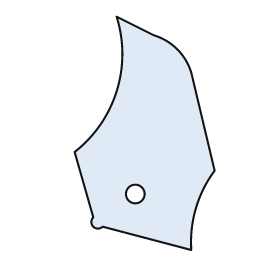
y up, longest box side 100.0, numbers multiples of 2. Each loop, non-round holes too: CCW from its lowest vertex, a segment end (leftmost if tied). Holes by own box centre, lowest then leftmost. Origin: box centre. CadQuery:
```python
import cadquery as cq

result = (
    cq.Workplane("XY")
    .moveTo(20.0, -50.0)
    .threePointArc((22.0, -32.0), (30.0, -16.0))
    .lineTo(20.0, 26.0)
    .threePointArc((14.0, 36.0), (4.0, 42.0))
    .lineTo(-12.0, 50.0)
    .threePointArc((-12.0, 18.0), (-30.0, -8.0))
    .lineTo(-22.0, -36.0)
    .threePointArc((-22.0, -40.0), (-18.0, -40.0))
    .close()
    .moveTo(-4.0, -26.0)
    .circle(4.0)
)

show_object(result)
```